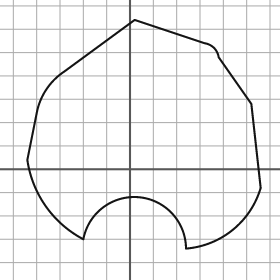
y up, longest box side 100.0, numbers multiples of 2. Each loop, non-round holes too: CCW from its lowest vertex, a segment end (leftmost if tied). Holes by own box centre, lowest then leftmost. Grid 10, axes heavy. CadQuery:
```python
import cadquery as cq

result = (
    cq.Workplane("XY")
    .moveTo(24.0, -34.0)
    .threePointArc((44.0, -26.0), (56.0, -8.0))
    .lineTo(52.0, 28.0)
    .lineTo(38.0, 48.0)
    .threePointArc((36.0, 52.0), (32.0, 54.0))
    .lineTo(2.0, 64.0)
    .lineTo(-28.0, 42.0)
    .threePointArc((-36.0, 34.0), (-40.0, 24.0))
    .lineTo(-44.0, 4.0)
    .threePointArc((-36.0, -16.0), (-20.0, -30.0))
    .threePointArc((4.0, -12.0), (24.0, -34.0))
    .close()
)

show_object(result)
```